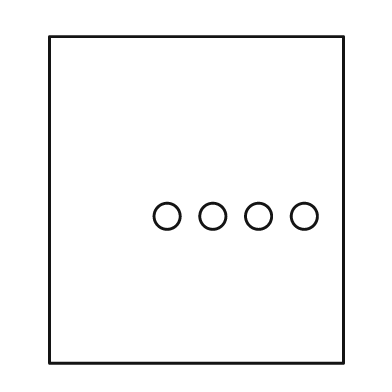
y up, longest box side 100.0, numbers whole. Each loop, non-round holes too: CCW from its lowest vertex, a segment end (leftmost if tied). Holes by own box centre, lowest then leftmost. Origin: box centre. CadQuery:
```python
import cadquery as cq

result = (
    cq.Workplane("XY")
    .moveTo(-45.0, -50.0)
    .lineTo(45.0, -50.0)
    .lineTo(45.0, 50.0)
    .lineTo(-45.0, 50.0)
    .close()
    .moveTo(-9.0, -5.0)
    .circle(4.0)
    .moveTo(5.0, -5.0)
    .circle(4.0)
    .moveTo(19.0, -5.0)
    .circle(4.0)
    .moveTo(33.0, -5.0)
    .circle(4.0)
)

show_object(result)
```